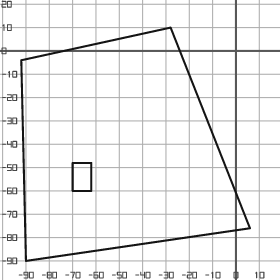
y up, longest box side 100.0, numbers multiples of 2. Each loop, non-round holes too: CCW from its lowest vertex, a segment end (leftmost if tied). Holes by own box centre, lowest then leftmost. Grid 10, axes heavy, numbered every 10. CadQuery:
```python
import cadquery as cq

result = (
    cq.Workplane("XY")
    .moveTo(-90.0, -90.0)
    .lineTo(6.0, -76.0)
    .lineTo(-28.0, 10.0)
    .lineTo(-92.0, -4.0)
    .close()
    .moveTo(-70.0, -60.0)
    .lineTo(-62.0, -60.0)
    .lineTo(-62.0, -48.0)
    .lineTo(-70.0, -48.0)
    .close()
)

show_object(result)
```